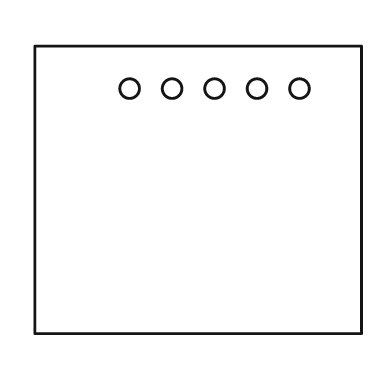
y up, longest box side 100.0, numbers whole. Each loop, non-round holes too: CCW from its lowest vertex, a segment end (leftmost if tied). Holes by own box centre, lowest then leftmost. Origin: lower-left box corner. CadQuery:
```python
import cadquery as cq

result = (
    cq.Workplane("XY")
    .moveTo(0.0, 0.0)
    .lineTo(100.0, 0.0)
    .lineTo(100.0, 88.0)
    .lineTo(0.0, 88.0)
    .close()
    .moveTo(29.0, 75.0)
    .circle(3.0)
    .moveTo(42.0, 75.0)
    .circle(3.0)
    .moveTo(55.0, 75.0)
    .circle(3.0)
    .moveTo(68.0, 75.0)
    .circle(3.0)
    .moveTo(81.0, 75.0)
    .circle(3.0)
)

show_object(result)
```